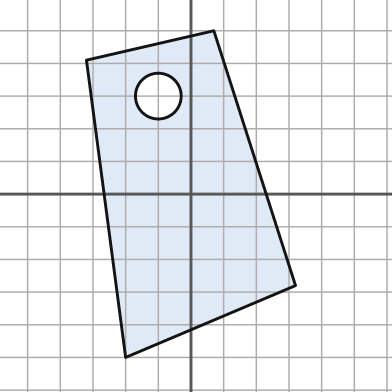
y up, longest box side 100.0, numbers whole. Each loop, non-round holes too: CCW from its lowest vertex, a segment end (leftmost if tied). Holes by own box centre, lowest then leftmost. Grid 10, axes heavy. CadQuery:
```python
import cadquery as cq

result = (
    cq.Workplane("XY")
    .moveTo(-20.0, -50.0)
    .lineTo(32.0, -28.0)
    .lineTo(7.0, 50.0)
    .lineTo(-32.0, 41.0)
    .close()
    .moveTo(-10.0, 30.0)
    .circle(7.0)
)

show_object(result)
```